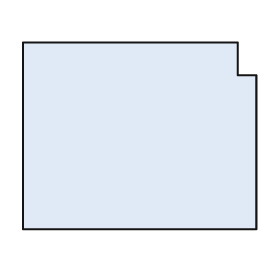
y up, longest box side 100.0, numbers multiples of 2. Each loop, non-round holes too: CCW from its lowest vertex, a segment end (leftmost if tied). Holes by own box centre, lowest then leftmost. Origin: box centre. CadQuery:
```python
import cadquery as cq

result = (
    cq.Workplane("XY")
    .moveTo(-50.0, -40.0)
    .lineTo(50.0, -40.0)
    .lineTo(50.0, 26.0)
    .lineTo(42.0, 26.0)
    .lineTo(42.0, 40.0)
    .lineTo(-50.0, 40.0)
    .close()
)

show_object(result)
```